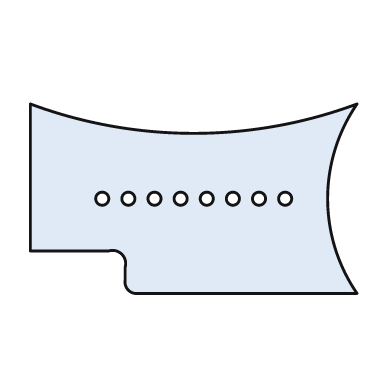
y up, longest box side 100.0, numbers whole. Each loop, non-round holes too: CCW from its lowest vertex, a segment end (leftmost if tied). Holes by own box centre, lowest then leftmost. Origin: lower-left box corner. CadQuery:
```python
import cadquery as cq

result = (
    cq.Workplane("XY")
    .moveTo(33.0, 0.0)
    .lineTo(100.0, 0.0)
    .threePointArc((91.0, 29.0), (100.0, 58.0))
    .threePointArc((50.0, 49.0), (0.0, 58.0))
    .lineTo(0.0, 13.0)
    .lineTo(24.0, 13.0)
    .threePointArc((28.0, 12.0), (29.0, 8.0))
    .lineTo(29.0, 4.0)
    .threePointArc((30.0, 1.0), (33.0, 0.0))
    .close()
    .moveTo(22.0, 29.0)
    .circle(2.0)
    .moveTo(30.0, 29.0)
    .circle(2.0)
    .moveTo(38.0, 29.0)
    .circle(2.0)
    .moveTo(46.0, 29.0)
    .circle(2.0)
    .moveTo(54.0, 29.0)
    .circle(2.0)
    .moveTo(62.0, 29.0)
    .circle(2.0)
    .moveTo(70.0, 29.0)
    .circle(2.0)
    .moveTo(78.0, 29.0)
    .circle(2.0)
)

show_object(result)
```